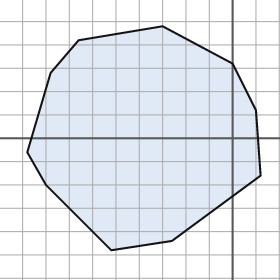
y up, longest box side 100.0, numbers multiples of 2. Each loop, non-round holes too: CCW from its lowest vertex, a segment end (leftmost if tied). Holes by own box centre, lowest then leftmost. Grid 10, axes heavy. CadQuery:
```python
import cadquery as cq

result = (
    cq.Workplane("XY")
    .moveTo(-52.0, -48.0)
    .lineTo(-26.0, -44.0)
    .lineTo(12.0, -16.0)
    .lineTo(10.0, 12.0)
    .lineTo(0.0, 32.0)
    .lineTo(-30.0, 48.0)
    .lineTo(-66.0, 42.0)
    .lineTo(-78.0, 28.0)
    .lineTo(-88.0, -6.0)
    .lineTo(-80.0, -20.0)
    .close()
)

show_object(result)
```